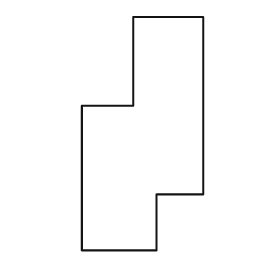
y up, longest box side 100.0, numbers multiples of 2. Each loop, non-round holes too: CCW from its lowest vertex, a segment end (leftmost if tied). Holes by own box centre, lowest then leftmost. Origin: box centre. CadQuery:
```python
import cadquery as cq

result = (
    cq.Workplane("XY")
    .moveTo(-26.0, -50.0)
    .lineTo(6.0, -50.0)
    .lineTo(6.0, -26.0)
    .lineTo(26.0, -26.0)
    .lineTo(26.0, 50.0)
    .lineTo(-4.0, 50.0)
    .lineTo(-4.0, 12.0)
    .lineTo(-26.0, 12.0)
    .close()
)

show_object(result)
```